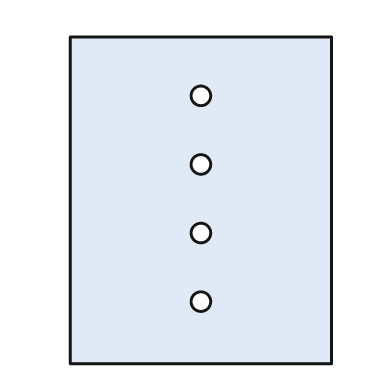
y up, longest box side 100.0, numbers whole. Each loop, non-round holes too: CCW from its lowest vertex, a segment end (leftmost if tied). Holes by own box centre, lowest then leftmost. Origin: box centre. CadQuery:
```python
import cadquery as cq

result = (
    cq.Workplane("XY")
    .moveTo(-40.0, -50.0)
    .lineTo(40.0, -50.0)
    .lineTo(40.0, 50.0)
    .lineTo(-40.0, 50.0)
    .close()
    .moveTo(0.0, -31.0)
    .circle(3.0)
    .moveTo(0.0, -10.0)
    .circle(3.0)
    .moveTo(0.0, 11.0)
    .circle(3.0)
    .moveTo(0.0, 32.0)
    .circle(3.0)
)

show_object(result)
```